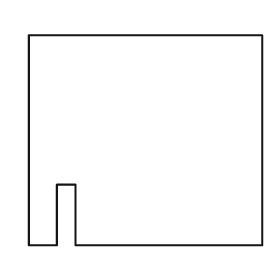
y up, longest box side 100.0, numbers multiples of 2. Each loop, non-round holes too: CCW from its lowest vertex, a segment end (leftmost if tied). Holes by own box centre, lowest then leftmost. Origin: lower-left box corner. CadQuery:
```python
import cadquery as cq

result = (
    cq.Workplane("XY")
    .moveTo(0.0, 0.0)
    .lineTo(12.0, 0.0)
    .lineTo(12.0, 26.0)
    .lineTo(20.0, 26.0)
    .lineTo(20.0, 0.0)
    .lineTo(100.0, 0.0)
    .lineTo(100.0, 90.0)
    .lineTo(0.0, 90.0)
    .close()
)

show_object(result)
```